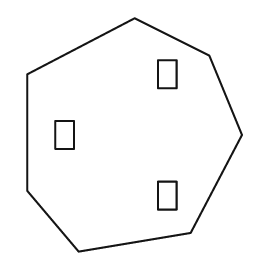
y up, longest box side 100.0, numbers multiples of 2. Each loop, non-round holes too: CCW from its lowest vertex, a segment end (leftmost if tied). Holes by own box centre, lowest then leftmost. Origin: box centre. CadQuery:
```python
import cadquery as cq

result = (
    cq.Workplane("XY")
    .moveTo(-24.0, -50.0)
    .lineTo(24.0, -42.0)
    .lineTo(46.0, 0.0)
    .lineTo(32.0, 34.0)
    .lineTo(0.0, 50.0)
    .lineTo(-46.0, 26.0)
    .lineTo(-46.0, -24.0)
    .close()
    .moveTo(10.0, -32.0)
    .lineTo(18.0, -32.0)
    .lineTo(18.0, -20.0)
    .lineTo(10.0, -20.0)
    .close()
    .moveTo(-34.0, -6.0)
    .lineTo(-26.0, -6.0)
    .lineTo(-26.0, 6.0)
    .lineTo(-34.0, 6.0)
    .close()
    .moveTo(10.0, 20.0)
    .lineTo(18.0, 20.0)
    .lineTo(18.0, 32.0)
    .lineTo(10.0, 32.0)
    .close()
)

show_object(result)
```